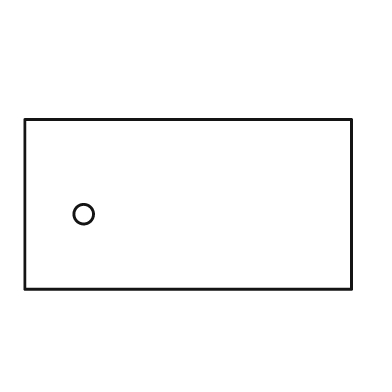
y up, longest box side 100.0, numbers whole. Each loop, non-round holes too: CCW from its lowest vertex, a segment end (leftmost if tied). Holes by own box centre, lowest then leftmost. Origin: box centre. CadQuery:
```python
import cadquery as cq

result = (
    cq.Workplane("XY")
    .moveTo(-50.0, -26.0)
    .lineTo(50.0, -26.0)
    .lineTo(50.0, 26.0)
    .lineTo(-50.0, 26.0)
    .close()
    .moveTo(-32.0, -3.0)
    .circle(3.0)
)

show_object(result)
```